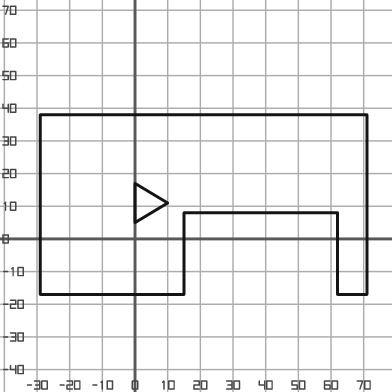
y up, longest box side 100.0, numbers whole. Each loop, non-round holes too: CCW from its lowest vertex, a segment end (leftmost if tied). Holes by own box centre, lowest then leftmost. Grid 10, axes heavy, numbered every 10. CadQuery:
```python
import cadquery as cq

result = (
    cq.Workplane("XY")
    .moveTo(-29.0, -17.0)
    .lineTo(15.0, -17.0)
    .lineTo(15.0, 8.0)
    .lineTo(62.0, 8.0)
    .lineTo(62.0, -17.0)
    .lineTo(71.0, -17.0)
    .lineTo(71.0, 38.0)
    .lineTo(-29.0, 38.0)
    .close()
    .moveTo(0.0, 5.0)
    .lineTo(10.0, 11.0)
    .lineTo(0.0, 17.0)
    .close()
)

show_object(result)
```